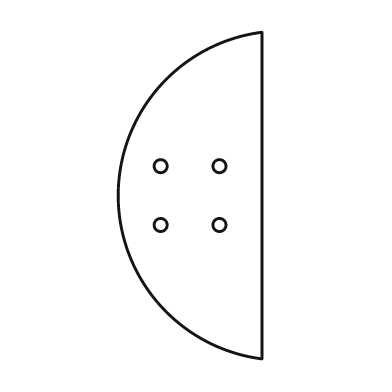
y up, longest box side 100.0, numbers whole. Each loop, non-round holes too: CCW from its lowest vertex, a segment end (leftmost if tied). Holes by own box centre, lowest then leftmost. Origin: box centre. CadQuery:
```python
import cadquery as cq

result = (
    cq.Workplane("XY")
    .moveTo(22.0, -50.0)
    .lineTo(22.0, 50.0)
    .threePointArc((-22.0, 0.0), (22.0, -50.0))
    .close()
    .moveTo(-9.0, -9.0)
    .circle(2.0)
    .moveTo(9.0, -9.0)
    .circle(2.0)
    .moveTo(-9.0, 9.0)
    .circle(2.0)
    .moveTo(9.0, 9.0)
    .circle(2.0)
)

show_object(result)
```